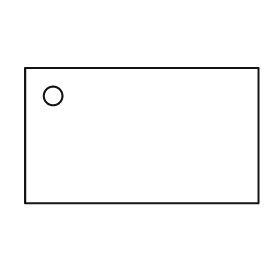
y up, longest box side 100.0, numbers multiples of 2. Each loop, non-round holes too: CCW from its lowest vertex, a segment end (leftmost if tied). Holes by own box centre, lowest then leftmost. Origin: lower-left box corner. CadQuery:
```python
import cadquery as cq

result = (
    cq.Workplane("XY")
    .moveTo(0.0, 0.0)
    .lineTo(100.0, 0.0)
    .lineTo(100.0, 58.0)
    .lineTo(0.0, 58.0)
    .close()
    .moveTo(12.0, 46.0)
    .circle(4.0)
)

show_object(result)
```